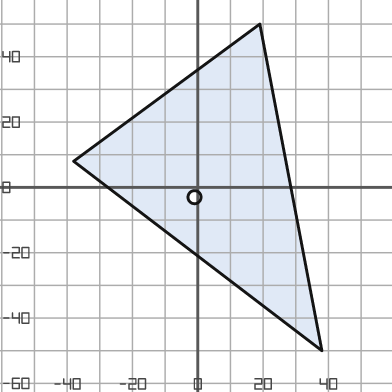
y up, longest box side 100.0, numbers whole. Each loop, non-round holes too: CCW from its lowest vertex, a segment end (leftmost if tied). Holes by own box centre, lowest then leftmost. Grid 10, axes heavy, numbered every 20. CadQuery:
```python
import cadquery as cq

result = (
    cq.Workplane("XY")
    .moveTo(38.0, -50.0)
    .lineTo(19.0, 50.0)
    .lineTo(-38.0, 8.0)
    .close()
    .moveTo(-1.0, -3.0)
    .circle(2.0)
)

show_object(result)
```